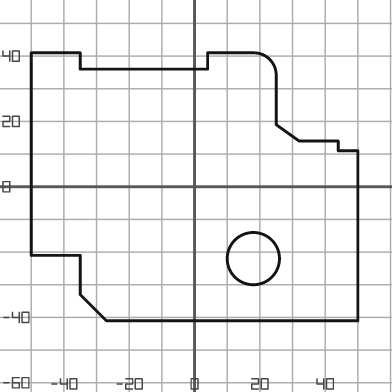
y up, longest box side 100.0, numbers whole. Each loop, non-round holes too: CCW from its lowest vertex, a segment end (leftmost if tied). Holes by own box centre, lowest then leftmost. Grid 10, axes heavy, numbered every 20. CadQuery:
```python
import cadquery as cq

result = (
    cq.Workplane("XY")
    .moveTo(-27.0, -41.0)
    .lineTo(50.0, -41.0)
    .lineTo(50.0, 11.0)
    .lineTo(44.0, 11.0)
    .lineTo(44.0, 14.0)
    .lineTo(32.0, 14.0)
    .lineTo(25.0, 19.0)
    .lineTo(25.0, 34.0)
    .threePointArc((23.0, 39.0), (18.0, 41.0))
    .lineTo(4.0, 41.0)
    .lineTo(4.0, 36.0)
    .lineTo(-35.0, 36.0)
    .lineTo(-35.0, 41.0)
    .lineTo(-50.0, 41.0)
    .lineTo(-50.0, -21.0)
    .lineTo(-35.0, -21.0)
    .lineTo(-35.0, -33.0)
    .close()
    .moveTo(18.0, -22.0)
    .circle(8.0)
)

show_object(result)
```